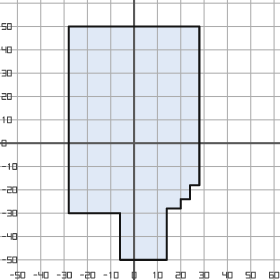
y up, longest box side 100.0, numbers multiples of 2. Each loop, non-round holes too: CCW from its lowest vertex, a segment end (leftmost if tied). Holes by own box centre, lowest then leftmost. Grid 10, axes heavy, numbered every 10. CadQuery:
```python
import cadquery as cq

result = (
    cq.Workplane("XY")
    .moveTo(-6.0, -50.0)
    .lineTo(14.0, -50.0)
    .lineTo(14.0, -28.0)
    .lineTo(20.0, -28.0)
    .lineTo(20.0, -24.0)
    .lineTo(24.0, -24.0)
    .lineTo(24.0, -18.0)
    .lineTo(28.0, -18.0)
    .lineTo(28.0, 50.0)
    .lineTo(-28.0, 50.0)
    .lineTo(-28.0, -30.0)
    .lineTo(-6.0, -30.0)
    .close()
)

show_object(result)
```